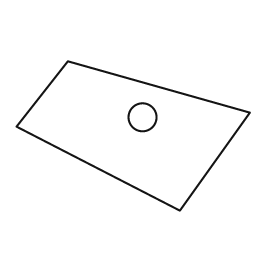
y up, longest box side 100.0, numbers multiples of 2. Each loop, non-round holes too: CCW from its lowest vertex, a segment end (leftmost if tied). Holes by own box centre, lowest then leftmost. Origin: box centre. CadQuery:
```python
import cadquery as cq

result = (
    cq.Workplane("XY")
    .moveTo(20.0, -32.0)
    .lineTo(50.0, 10.0)
    .lineTo(-28.0, 32.0)
    .lineTo(-50.0, 4.0)
    .close()
    .moveTo(4.0, 8.0)
    .circle(6.0)
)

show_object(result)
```